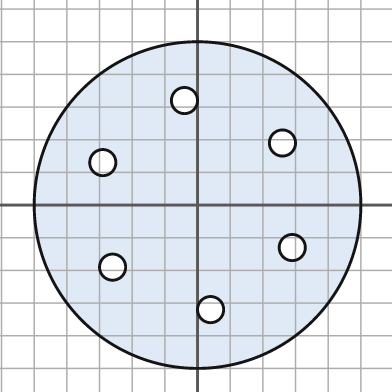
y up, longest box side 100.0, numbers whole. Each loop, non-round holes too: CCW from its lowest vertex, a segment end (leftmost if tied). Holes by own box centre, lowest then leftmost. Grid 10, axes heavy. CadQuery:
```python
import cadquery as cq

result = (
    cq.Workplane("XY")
    .moveTo(0.0, 0.0)
    .circle(50.0)
    .moveTo(4.0, -32.0)
    .circle(4.0)
    .moveTo(-26.0, -19.0)
    .circle(4.0)
    .moveTo(29.0, -13.0)
    .circle(4.0)
    .moveTo(-29.0, 13.0)
    .circle(4.0)
    .moveTo(26.0, 19.0)
    .circle(4.0)
    .moveTo(-4.0, 32.0)
    .circle(4.0)
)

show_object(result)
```